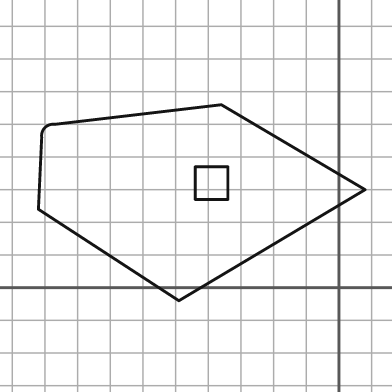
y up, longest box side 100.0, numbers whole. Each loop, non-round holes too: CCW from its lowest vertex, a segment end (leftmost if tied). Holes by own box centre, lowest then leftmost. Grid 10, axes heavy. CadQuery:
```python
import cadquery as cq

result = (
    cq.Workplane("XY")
    .moveTo(-49.0, -4.0)
    .lineTo(8.0, 30.0)
    .lineTo(-36.0, 56.0)
    .lineTo(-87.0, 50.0)
    .threePointArc((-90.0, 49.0), (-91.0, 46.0))
    .lineTo(-92.0, 24.0)
    .close()
    .moveTo(-44.0, 27.0)
    .lineTo(-34.0, 27.0)
    .lineTo(-34.0, 37.0)
    .lineTo(-44.0, 37.0)
    .close()
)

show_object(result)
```